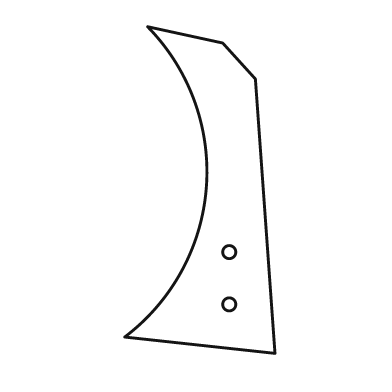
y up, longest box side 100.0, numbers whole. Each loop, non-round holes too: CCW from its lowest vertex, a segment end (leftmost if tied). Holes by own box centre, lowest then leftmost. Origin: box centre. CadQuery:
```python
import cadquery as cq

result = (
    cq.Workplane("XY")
    .moveTo(23.0, -50.0)
    .lineTo(17.0, 34.0)
    .lineTo(7.0, 45.0)
    .lineTo(-16.0, 50.0)
    .threePointArc((2.0, 1.0), (-23.0, -45.0))
    .close()
    .moveTo(9.0, -35.0)
    .circle(2.0)
    .moveTo(9.0, -19.0)
    .circle(2.0)
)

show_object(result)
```